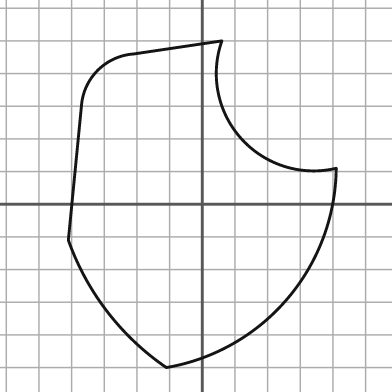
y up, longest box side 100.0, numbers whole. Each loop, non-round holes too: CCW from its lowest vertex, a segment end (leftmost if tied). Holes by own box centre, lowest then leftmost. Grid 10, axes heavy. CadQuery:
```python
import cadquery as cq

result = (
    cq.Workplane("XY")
    .moveTo(-11.0, -50.0)
    .threePointArc((26.0, -29.0), (41.0, 11.0))
    .threePointArc((12.0, 20.0), (6.0, 50.0))
    .lineTo(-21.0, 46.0)
    .threePointArc((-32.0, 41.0), (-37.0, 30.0))
    .lineTo(-41.0, -11.0)
    .threePointArc((-29.0, -33.0), (-11.0, -50.0))
    .close()
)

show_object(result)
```